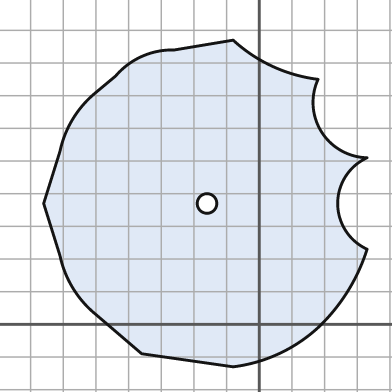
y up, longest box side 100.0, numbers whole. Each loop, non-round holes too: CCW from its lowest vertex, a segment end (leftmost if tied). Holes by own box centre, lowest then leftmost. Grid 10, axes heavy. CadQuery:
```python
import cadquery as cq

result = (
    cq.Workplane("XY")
    .moveTo(-8.0, -13.0)
    .threePointArc((6.0, -9.0), (18.0, -1.0))
    .threePointArc((27.0, 10.0), (33.0, 23.0))
    .threePointArc((24.0, 37.0), (33.0, 51.0))
    .threePointArc((19.0, 59.0), (18.0, 75.0))
    .threePointArc((4.0, 79.0), (-8.0, 87.0))
    .lineTo(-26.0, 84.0)
    .threePointArc((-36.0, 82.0), (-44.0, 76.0))
    .lineTo(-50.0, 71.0)
    .threePointArc((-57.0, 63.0), (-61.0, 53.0))
    .lineTo(-66.0, 37.0)
    .lineTo(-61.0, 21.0)
    .threePointArc((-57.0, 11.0), (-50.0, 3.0))
    .lineTo(-36.0, -9.0)
    .close()
    .moveTo(-16.0, 37.0)
    .circle(3.0)
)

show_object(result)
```